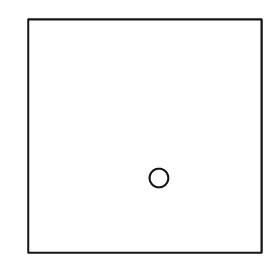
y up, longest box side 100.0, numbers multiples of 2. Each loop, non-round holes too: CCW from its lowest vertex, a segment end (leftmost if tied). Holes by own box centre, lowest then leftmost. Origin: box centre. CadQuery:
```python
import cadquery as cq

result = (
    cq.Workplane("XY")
    .moveTo(-50.0, -50.0)
    .lineTo(50.0, -50.0)
    .lineTo(50.0, 50.0)
    .lineTo(-50.0, 50.0)
    .close()
    .moveTo(6.0, -18.0)
    .circle(4.0)
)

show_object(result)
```